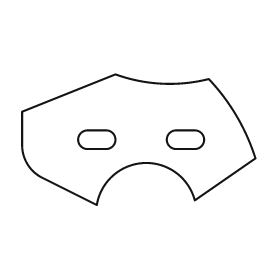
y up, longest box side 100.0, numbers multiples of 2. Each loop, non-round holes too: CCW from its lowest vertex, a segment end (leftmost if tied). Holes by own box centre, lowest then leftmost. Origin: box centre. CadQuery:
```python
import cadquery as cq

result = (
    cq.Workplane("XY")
    .moveTo(-18.0, -28.0)
    .threePointArc((2.0, -10.0), (24.0, -26.0))
    .lineTo(50.0, -8.0)
    .threePointArc((42.0, 10.0), (30.0, 26.0))
    .threePointArc((10.0, 24.0), (-10.0, 28.0))
    .lineTo(-50.0, 12.0)
    .lineTo(-50.0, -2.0)
    .threePointArc((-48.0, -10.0), (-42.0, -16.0))
    .close()
    .moveTo(-22.0, -4.0)
    .lineTo(-14.0, -4.0)
    .threePointArc((-10.0, 0.0), (-14.0, 4.0))
    .lineTo(-22.0, 4.0)
    .threePointArc((-26.0, 0.0), (-22.0, -4.0))
    .close()
    .moveTo(16.0, -4.0)
    .lineTo(24.0, -4.0)
    .threePointArc((28.0, 0.0), (24.0, 4.0))
    .lineTo(16.0, 4.0)
    .threePointArc((12.0, 0.0), (16.0, -4.0))
    .close()
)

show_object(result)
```